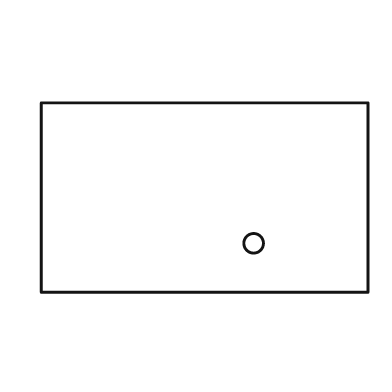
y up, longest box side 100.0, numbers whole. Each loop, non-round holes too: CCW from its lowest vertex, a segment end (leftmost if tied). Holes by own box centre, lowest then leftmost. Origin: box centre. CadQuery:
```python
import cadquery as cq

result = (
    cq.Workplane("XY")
    .moveTo(-50.0, -29.0)
    .lineTo(50.0, -29.0)
    .lineTo(50.0, 29.0)
    .lineTo(-50.0, 29.0)
    .close()
    .moveTo(15.0, -14.0)
    .circle(3.0)
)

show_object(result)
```